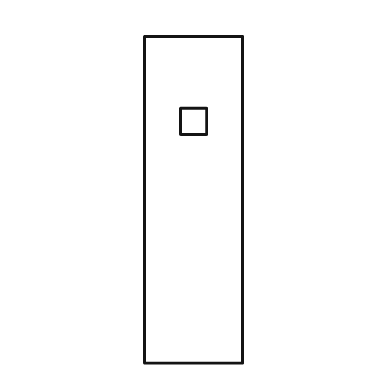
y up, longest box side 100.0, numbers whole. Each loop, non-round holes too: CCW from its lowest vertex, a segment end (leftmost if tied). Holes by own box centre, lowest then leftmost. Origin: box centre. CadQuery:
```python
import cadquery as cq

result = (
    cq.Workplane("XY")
    .moveTo(-15.0, -50.0)
    .lineTo(15.0, -50.0)
    .lineTo(15.0, 50.0)
    .lineTo(-15.0, 50.0)
    .close()
    .moveTo(-4.0, 20.0)
    .lineTo(4.0, 20.0)
    .lineTo(4.0, 28.0)
    .lineTo(-4.0, 28.0)
    .close()
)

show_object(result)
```